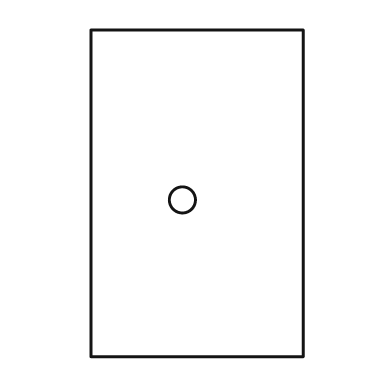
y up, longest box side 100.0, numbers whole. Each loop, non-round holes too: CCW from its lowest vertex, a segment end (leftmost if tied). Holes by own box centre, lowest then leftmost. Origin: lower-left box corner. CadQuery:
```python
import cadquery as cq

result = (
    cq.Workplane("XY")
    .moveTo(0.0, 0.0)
    .lineTo(65.0, 0.0)
    .lineTo(65.0, 100.0)
    .lineTo(0.0, 100.0)
    .close()
    .moveTo(28.0, 48.0)
    .circle(4.0)
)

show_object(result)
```